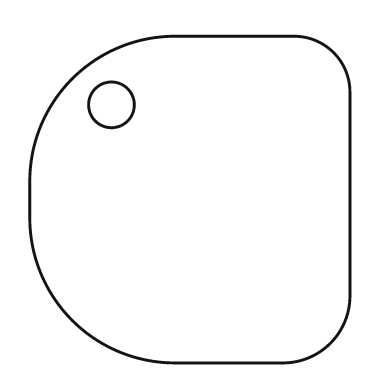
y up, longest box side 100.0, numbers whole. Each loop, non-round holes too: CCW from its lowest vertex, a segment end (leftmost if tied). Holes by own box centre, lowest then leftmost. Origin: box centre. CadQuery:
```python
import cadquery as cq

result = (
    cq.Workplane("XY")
    .moveTo(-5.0, -50.0)
    .lineTo(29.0, -50.0)
    .threePointArc((43.0, -44.0), (49.0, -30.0))
    .lineTo(49.0, 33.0)
    .threePointArc((44.0, 45.0), (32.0, 50.0))
    .lineTo(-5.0, 50.0)
    .threePointArc((-36.0, 37.0), (-49.0, 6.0))
    .lineTo(-49.0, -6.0)
    .threePointArc((-36.0, -37.0), (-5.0, -50.0))
    .close()
    .moveTo(-24.0, 29.0)
    .circle(7.0)
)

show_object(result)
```